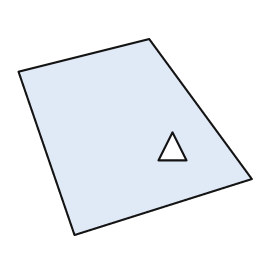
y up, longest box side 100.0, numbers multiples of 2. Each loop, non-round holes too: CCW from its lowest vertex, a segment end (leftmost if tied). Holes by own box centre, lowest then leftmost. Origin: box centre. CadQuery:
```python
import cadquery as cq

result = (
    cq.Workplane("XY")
    .moveTo(-26.0, -42.0)
    .lineTo(50.0, -18.0)
    .lineTo(6.0, 42.0)
    .lineTo(-50.0, 28.0)
    .close()
    .moveTo(10.0, -10.0)
    .lineTo(22.0, -10.0)
    .lineTo(16.0, 2.0)
    .close()
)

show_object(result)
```